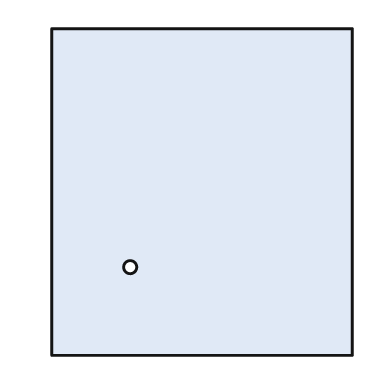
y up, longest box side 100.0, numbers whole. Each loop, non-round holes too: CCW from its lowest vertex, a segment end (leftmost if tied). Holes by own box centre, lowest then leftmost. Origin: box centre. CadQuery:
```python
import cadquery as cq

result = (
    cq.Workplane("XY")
    .moveTo(-46.0, -50.0)
    .lineTo(46.0, -50.0)
    .lineTo(46.0, 50.0)
    .lineTo(-46.0, 50.0)
    .close()
    .moveTo(-22.0, -23.0)
    .circle(2.0)
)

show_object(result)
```